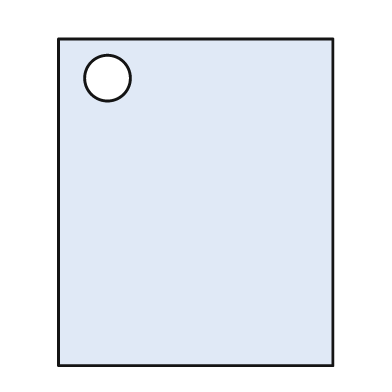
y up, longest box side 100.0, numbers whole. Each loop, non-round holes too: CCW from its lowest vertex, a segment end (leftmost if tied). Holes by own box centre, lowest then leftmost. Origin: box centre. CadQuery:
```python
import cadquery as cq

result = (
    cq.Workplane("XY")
    .moveTo(-42.0, -50.0)
    .lineTo(42.0, -50.0)
    .lineTo(42.0, 50.0)
    .lineTo(-42.0, 50.0)
    .close()
    .moveTo(-27.0, 38.0)
    .circle(7.0)
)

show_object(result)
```